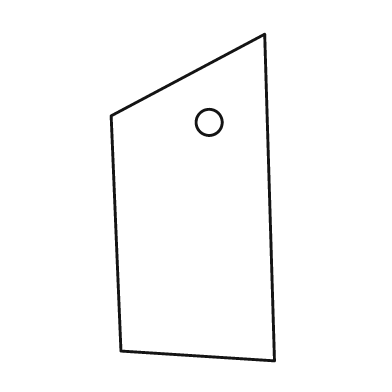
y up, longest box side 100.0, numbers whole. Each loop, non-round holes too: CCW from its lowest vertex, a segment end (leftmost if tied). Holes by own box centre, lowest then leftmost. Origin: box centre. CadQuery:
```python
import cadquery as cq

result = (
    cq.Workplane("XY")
    .moveTo(25.0, -50.0)
    .lineTo(22.0, 50.0)
    .lineTo(-25.0, 25.0)
    .lineTo(-22.0, -47.0)
    .close()
    .moveTo(5.0, 23.0)
    .circle(4.0)
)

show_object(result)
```